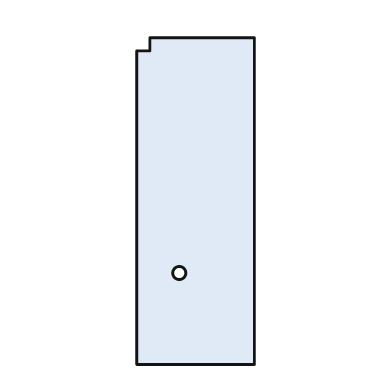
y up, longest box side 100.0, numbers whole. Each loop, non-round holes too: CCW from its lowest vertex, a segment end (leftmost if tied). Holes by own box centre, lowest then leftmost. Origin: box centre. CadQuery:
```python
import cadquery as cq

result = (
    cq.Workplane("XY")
    .moveTo(-18.0, -50.0)
    .lineTo(18.0, -50.0)
    .lineTo(18.0, 50.0)
    .lineTo(-14.0, 50.0)
    .lineTo(-14.0, 46.0)
    .lineTo(-18.0, 46.0)
    .close()
    .moveTo(-5.0, -22.0)
    .circle(2.0)
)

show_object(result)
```